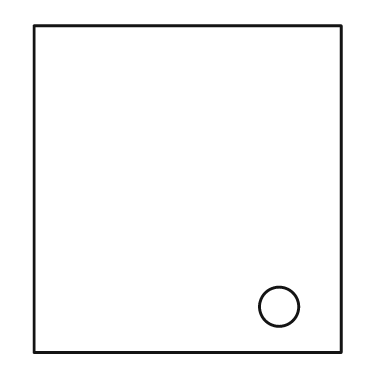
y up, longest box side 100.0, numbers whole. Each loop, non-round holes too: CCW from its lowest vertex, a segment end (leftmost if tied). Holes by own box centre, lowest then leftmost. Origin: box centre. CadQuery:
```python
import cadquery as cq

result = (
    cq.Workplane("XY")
    .moveTo(-47.0, -50.0)
    .lineTo(47.0, -50.0)
    .lineTo(47.0, 50.0)
    .lineTo(-47.0, 50.0)
    .close()
    .moveTo(28.0, -36.0)
    .circle(6.0)
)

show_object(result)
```